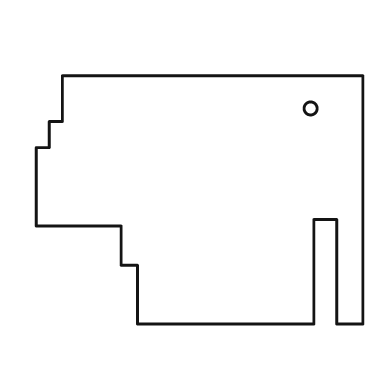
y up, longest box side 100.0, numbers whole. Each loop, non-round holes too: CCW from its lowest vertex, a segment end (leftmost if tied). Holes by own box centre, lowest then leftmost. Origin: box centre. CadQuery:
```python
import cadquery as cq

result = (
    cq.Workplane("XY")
    .moveTo(-19.0, -38.0)
    .lineTo(35.0, -38.0)
    .lineTo(35.0, -6.0)
    .lineTo(42.0, -6.0)
    .lineTo(42.0, -38.0)
    .lineTo(50.0, -38.0)
    .lineTo(50.0, 38.0)
    .lineTo(-42.0, 38.0)
    .lineTo(-42.0, 24.0)
    .lineTo(-46.0, 24.0)
    .lineTo(-46.0, 16.0)
    .lineTo(-50.0, 16.0)
    .lineTo(-50.0, -8.0)
    .lineTo(-24.0, -8.0)
    .lineTo(-24.0, -20.0)
    .lineTo(-19.0, -20.0)
    .close()
    .moveTo(34.0, 28.0)
    .circle(2.0)
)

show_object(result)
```